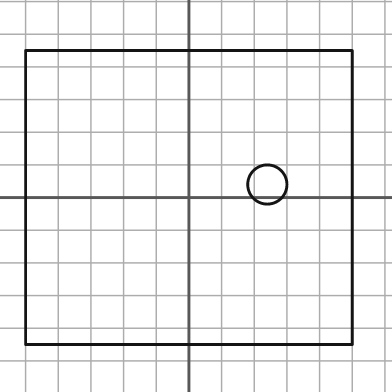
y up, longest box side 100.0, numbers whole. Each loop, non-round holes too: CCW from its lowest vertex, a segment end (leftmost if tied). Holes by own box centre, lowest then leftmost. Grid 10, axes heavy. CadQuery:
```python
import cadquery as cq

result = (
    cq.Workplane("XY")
    .moveTo(-50.0, -45.0)
    .lineTo(50.0, -45.0)
    .lineTo(50.0, 45.0)
    .lineTo(-50.0, 45.0)
    .close()
    .moveTo(24.0, 4.0)
    .circle(6.0)
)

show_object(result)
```